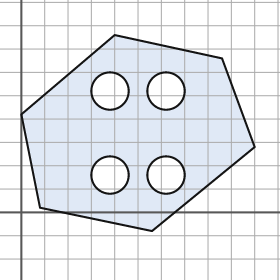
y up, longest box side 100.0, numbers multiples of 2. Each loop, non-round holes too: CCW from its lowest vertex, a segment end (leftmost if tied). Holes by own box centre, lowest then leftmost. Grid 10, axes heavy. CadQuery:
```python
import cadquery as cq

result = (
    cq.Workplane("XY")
    .moveTo(56.0, -8.0)
    .lineTo(100.0, 28.0)
    .lineTo(86.0, 66.0)
    .lineTo(40.0, 76.0)
    .lineTo(0.0, 42.0)
    .lineTo(8.0, 2.0)
    .close()
    .moveTo(38.0, 16.0)
    .circle(8.0)
    .moveTo(62.0, 16.0)
    .circle(8.0)
    .moveTo(38.0, 52.0)
    .circle(8.0)
    .moveTo(62.0, 52.0)
    .circle(8.0)
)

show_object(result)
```